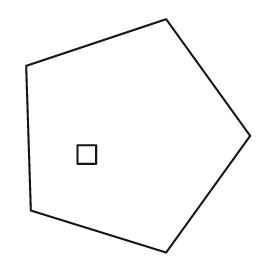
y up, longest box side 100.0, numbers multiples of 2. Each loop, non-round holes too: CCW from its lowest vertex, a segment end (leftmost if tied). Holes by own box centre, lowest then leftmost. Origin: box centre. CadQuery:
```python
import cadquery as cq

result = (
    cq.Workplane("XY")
    .moveTo(12.0, -50.0)
    .lineTo(48.0, 0.0)
    .lineTo(12.0, 50.0)
    .lineTo(-48.0, 30.0)
    .lineTo(-46.0, -32.0)
    .close()
    .moveTo(-26.0, -12.0)
    .lineTo(-18.0, -12.0)
    .lineTo(-18.0, -4.0)
    .lineTo(-26.0, -4.0)
    .close()
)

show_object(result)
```